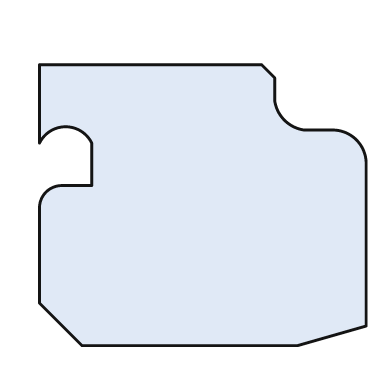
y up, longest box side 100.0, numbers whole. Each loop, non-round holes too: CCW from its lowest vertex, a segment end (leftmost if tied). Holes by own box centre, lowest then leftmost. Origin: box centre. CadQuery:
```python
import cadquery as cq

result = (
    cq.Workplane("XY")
    .moveTo(-37.0, -43.0)
    .lineTo(29.0, -43.0)
    .lineTo(50.0, -37.0)
    .lineTo(50.0, 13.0)
    .threePointArc((47.0, 20.0), (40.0, 23.0))
    .lineTo(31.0, 23.0)
    .threePointArc((25.0, 26.0), (22.0, 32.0))
    .lineTo(22.0, 39.0)
    .lineTo(18.0, 43.0)
    .lineTo(-50.0, 43.0)
    .lineTo(-50.0, 19.0)
    .threePointArc((-42.0, 24.0), (-34.0, 19.0))
    .lineTo(-34.0, 6.0)
    .lineTo(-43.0, 6.0)
    .threePointArc((-48.0, 4.0), (-50.0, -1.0))
    .lineTo(-50.0, -30.0)
    .close()
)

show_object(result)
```